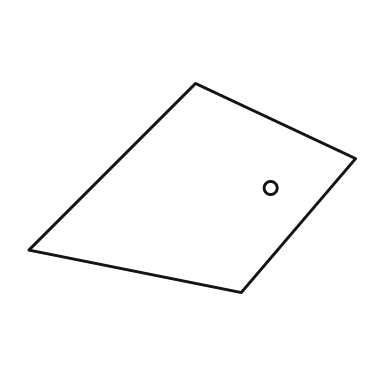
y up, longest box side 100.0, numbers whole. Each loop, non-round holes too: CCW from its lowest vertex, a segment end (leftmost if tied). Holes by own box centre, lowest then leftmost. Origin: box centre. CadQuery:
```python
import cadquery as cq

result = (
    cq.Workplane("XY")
    .moveTo(15.0, -32.0)
    .lineTo(50.0, 9.0)
    .lineTo(1.0, 32.0)
    .lineTo(-50.0, -19.0)
    .close()
    .moveTo(24.0, 0.0)
    .circle(2.0)
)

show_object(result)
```